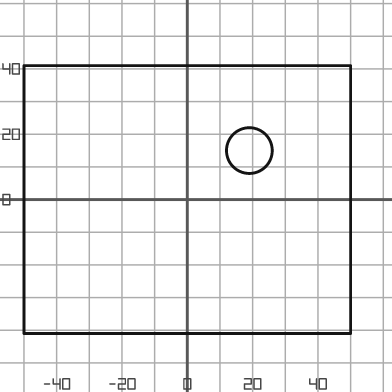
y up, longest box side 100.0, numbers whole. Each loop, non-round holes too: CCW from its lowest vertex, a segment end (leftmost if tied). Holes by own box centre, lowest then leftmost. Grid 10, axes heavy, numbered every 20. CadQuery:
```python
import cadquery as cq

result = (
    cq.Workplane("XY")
    .moveTo(-50.0, -41.0)
    .lineTo(50.0, -41.0)
    .lineTo(50.0, 41.0)
    .lineTo(-50.0, 41.0)
    .close()
    .moveTo(19.0, 15.0)
    .circle(7.0)
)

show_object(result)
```